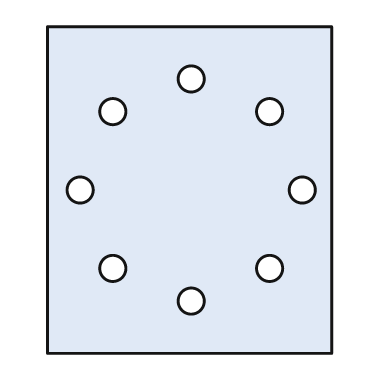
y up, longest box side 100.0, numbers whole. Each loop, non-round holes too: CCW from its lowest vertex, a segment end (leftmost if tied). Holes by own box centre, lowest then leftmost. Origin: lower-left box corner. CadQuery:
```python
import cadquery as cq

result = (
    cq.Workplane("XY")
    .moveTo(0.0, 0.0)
    .lineTo(87.0, 0.0)
    .lineTo(87.0, 100.0)
    .lineTo(0.0, 100.0)
    .close()
    .moveTo(44.0, 16.0)
    .circle(4.0)
    .moveTo(20.0, 26.0)
    .circle(4.0)
    .moveTo(68.0, 26.0)
    .circle(4.0)
    .moveTo(10.0, 50.0)
    .circle(4.0)
    .moveTo(78.0, 50.0)
    .circle(4.0)
    .moveTo(20.0, 74.0)
    .circle(4.0)
    .moveTo(68.0, 74.0)
    .circle(4.0)
    .moveTo(44.0, 84.0)
    .circle(4.0)
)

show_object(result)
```